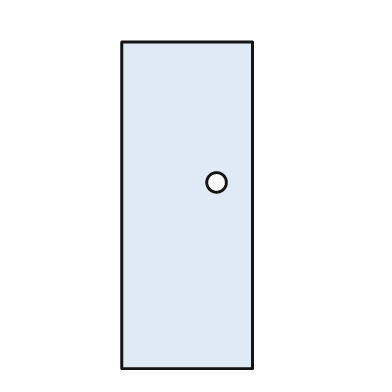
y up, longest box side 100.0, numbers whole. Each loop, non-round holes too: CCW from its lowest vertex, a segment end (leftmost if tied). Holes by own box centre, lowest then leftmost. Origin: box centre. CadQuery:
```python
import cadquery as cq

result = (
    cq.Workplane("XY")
    .moveTo(-20.0, -50.0)
    .lineTo(20.0, -50.0)
    .lineTo(20.0, 50.0)
    .lineTo(-20.0, 50.0)
    .close()
    .moveTo(9.0, 7.0)
    .circle(3.0)
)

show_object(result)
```